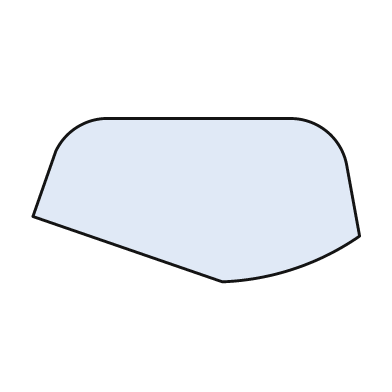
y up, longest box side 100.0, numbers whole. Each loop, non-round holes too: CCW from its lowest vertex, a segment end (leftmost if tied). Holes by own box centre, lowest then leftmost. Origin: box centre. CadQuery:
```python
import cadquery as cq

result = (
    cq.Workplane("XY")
    .moveTo(8.0, -25.0)
    .threePointArc((30.0, -21.0), (50.0, -11.0))
    .lineTo(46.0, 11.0)
    .threePointArc((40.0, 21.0), (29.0, 25.0))
    .lineTo(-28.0, 25.0)
    .threePointArc((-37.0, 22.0), (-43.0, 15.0))
    .lineTo(-50.0, -5.0)
    .close()
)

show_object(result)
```